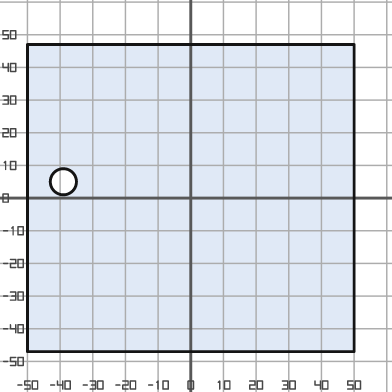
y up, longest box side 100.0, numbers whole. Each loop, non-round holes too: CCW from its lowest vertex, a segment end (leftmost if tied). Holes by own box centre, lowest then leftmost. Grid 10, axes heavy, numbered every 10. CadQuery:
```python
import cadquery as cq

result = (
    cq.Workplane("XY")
    .moveTo(-50.0, -47.0)
    .lineTo(50.0, -47.0)
    .lineTo(50.0, 47.0)
    .lineTo(-50.0, 47.0)
    .close()
    .moveTo(-39.0, 5.0)
    .circle(4.0)
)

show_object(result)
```